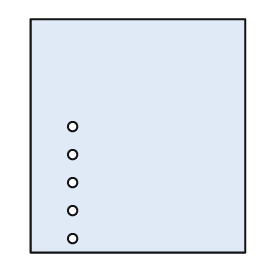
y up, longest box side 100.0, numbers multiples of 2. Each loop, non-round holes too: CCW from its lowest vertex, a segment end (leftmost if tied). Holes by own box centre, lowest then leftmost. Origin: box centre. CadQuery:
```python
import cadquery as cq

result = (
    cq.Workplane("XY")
    .moveTo(-46.0, -50.0)
    .lineTo(46.0, -50.0)
    .lineTo(46.0, 50.0)
    .lineTo(-46.0, 50.0)
    .close()
    .moveTo(-28.0, -44.0)
    .circle(2.0)
    .moveTo(-28.0, -32.0)
    .circle(2.0)
    .moveTo(-28.0, -20.0)
    .circle(2.0)
    .moveTo(-28.0, -8.0)
    .circle(2.0)
    .moveTo(-28.0, 4.0)
    .circle(2.0)
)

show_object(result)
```